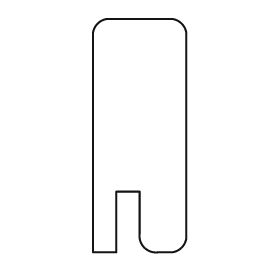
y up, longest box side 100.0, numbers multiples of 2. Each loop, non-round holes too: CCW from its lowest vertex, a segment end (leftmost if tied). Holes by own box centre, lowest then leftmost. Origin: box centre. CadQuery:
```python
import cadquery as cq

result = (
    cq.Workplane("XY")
    .moveTo(-20.0, -50.0)
    .lineTo(-10.0, -50.0)
    .lineTo(-10.0, -24.0)
    .lineTo(0.0, -24.0)
    .lineTo(0.0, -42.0)
    .threePointArc((2.0, -48.0), (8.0, -50.0))
    .lineTo(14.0, -50.0)
    .threePointArc((18.0, -48.0), (20.0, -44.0))
    .lineTo(20.0, 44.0)
    .threePointArc((18.0, 48.0), (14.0, 50.0))
    .lineTo(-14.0, 50.0)
    .threePointArc((-18.0, 48.0), (-20.0, 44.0))
    .close()
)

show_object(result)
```